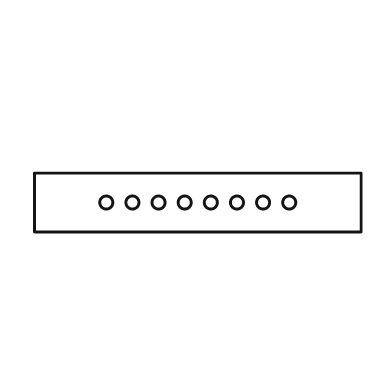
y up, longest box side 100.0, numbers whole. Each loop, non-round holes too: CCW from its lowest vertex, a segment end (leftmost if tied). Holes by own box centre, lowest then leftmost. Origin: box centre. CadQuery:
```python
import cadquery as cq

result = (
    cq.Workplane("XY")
    .moveTo(-50.0, -9.0)
    .lineTo(50.0, -9.0)
    .lineTo(50.0, 9.0)
    .lineTo(-50.0, 9.0)
    .close()
    .moveTo(-28.0, 0.0)
    .circle(2.0)
    .moveTo(-20.0, 0.0)
    .circle(2.0)
    .moveTo(-12.0, 0.0)
    .circle(2.0)
    .moveTo(-4.0, 0.0)
    .circle(2.0)
    .moveTo(4.0, 0.0)
    .circle(2.0)
    .moveTo(12.0, 0.0)
    .circle(2.0)
    .moveTo(20.0, 0.0)
    .circle(2.0)
    .moveTo(28.0, 0.0)
    .circle(2.0)
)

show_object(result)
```